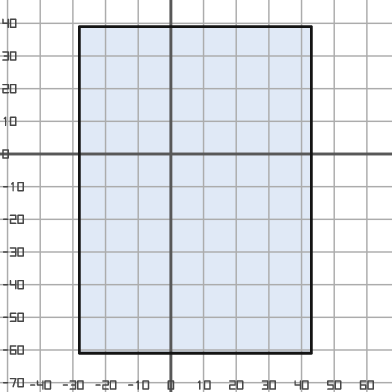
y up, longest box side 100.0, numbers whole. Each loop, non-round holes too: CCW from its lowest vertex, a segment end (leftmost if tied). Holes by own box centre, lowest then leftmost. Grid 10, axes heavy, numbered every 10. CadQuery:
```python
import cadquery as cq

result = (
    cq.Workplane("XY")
    .moveTo(-28.0, -61.0)
    .lineTo(43.0, -61.0)
    .lineTo(43.0, 39.0)
    .lineTo(-28.0, 39.0)
    .close()
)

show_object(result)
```